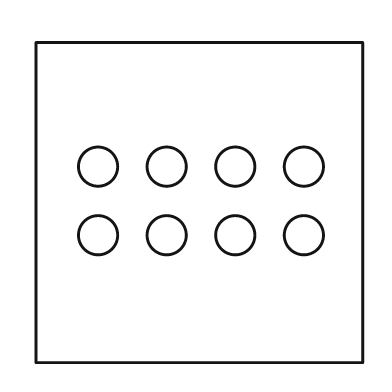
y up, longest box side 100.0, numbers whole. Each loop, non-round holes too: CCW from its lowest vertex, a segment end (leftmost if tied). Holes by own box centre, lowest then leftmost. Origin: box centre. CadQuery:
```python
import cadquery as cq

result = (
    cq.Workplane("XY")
    .moveTo(-50.0, -49.0)
    .lineTo(50.0, -49.0)
    .lineTo(50.0, 49.0)
    .lineTo(-50.0, 49.0)
    .close()
    .moveTo(-31.0, -10.0)
    .circle(6.0)
    .moveTo(-10.0, -10.0)
    .circle(6.0)
    .moveTo(11.0, -10.0)
    .circle(6.0)
    .moveTo(32.0, -10.0)
    .circle(6.0)
    .moveTo(-31.0, 11.0)
    .circle(6.0)
    .moveTo(-10.0, 11.0)
    .circle(6.0)
    .moveTo(11.0, 11.0)
    .circle(6.0)
    .moveTo(32.0, 11.0)
    .circle(6.0)
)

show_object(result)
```